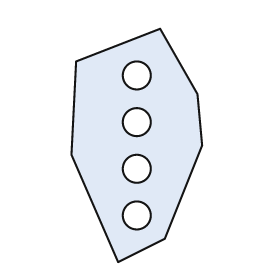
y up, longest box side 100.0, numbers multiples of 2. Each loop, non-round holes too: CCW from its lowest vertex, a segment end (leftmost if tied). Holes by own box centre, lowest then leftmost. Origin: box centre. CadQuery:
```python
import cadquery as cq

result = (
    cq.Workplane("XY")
    .moveTo(-8.0, -50.0)
    .lineTo(12.0, -40.0)
    .lineTo(28.0, 0.0)
    .lineTo(26.0, 22.0)
    .lineTo(10.0, 50.0)
    .lineTo(-26.0, 36.0)
    .lineTo(-28.0, -4.0)
    .close()
    .moveTo(0.0, -30.0)
    .circle(6.0)
    .moveTo(0.0, -10.0)
    .circle(6.0)
    .moveTo(0.0, 10.0)
    .circle(6.0)
    .moveTo(0.0, 30.0)
    .circle(6.0)
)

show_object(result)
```